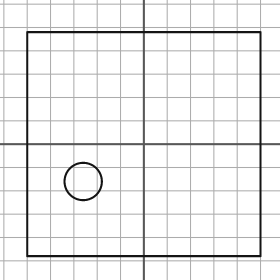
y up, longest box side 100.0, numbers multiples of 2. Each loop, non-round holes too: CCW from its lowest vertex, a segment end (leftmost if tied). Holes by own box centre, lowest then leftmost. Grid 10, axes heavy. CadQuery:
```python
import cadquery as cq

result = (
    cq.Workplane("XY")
    .moveTo(-50.0, -48.0)
    .lineTo(50.0, -48.0)
    .lineTo(50.0, 48.0)
    .lineTo(-50.0, 48.0)
    .close()
    .moveTo(-26.0, -16.0)
    .circle(8.0)
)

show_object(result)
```